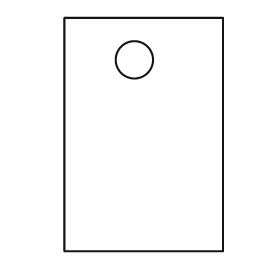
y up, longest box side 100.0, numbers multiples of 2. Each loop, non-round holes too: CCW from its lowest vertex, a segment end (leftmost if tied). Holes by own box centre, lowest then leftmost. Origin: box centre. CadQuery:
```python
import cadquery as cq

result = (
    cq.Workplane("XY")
    .moveTo(-34.0, -50.0)
    .lineTo(34.0, -50.0)
    .lineTo(34.0, 50.0)
    .lineTo(-34.0, 50.0)
    .close()
    .moveTo(-4.0, 32.0)
    .circle(8.0)
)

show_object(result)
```